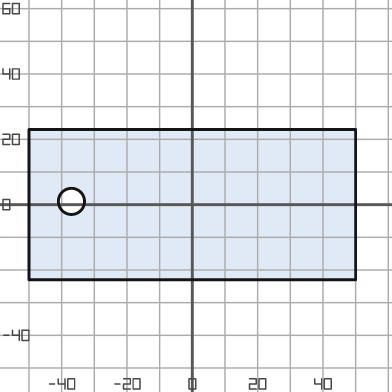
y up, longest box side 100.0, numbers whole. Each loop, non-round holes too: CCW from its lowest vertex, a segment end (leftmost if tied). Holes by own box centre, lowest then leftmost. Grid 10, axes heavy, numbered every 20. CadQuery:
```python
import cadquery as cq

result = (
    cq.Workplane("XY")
    .moveTo(-50.0, -23.0)
    .lineTo(50.0, -23.0)
    .lineTo(50.0, 23.0)
    .lineTo(-50.0, 23.0)
    .close()
    .moveTo(-37.0, 1.0)
    .circle(4.0)
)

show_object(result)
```